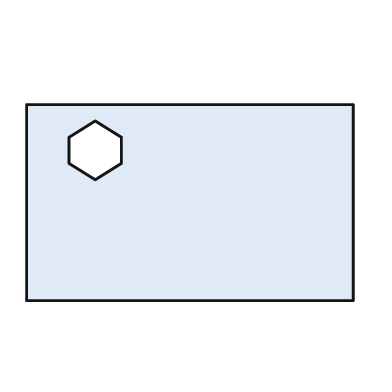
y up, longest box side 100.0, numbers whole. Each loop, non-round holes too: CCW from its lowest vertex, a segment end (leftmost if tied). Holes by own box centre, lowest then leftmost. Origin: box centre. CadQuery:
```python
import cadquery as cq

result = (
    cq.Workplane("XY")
    .moveTo(-50.0, -30.0)
    .lineTo(50.0, -30.0)
    .lineTo(50.0, 30.0)
    .lineTo(-50.0, 30.0)
    .close()
    .moveTo(-29.0, 7.0)
    .lineTo(-21.0, 12.0)
    .lineTo(-21.0, 20.0)
    .lineTo(-29.0, 25.0)
    .lineTo(-37.0, 20.0)
    .lineTo(-37.0, 12.0)
    .close()
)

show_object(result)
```